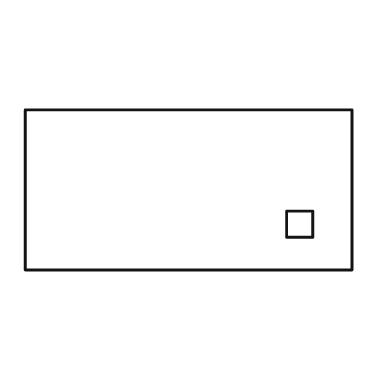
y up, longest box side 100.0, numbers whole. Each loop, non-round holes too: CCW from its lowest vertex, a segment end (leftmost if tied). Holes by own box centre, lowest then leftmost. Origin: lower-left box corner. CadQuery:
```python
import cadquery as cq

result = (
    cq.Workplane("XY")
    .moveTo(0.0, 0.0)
    .lineTo(100.0, 0.0)
    .lineTo(100.0, 49.0)
    .lineTo(0.0, 49.0)
    .close()
    .moveTo(80.0, 10.0)
    .lineTo(88.0, 10.0)
    .lineTo(88.0, 18.0)
    .lineTo(80.0, 18.0)
    .close()
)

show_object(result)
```